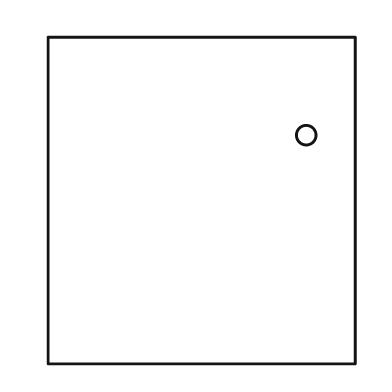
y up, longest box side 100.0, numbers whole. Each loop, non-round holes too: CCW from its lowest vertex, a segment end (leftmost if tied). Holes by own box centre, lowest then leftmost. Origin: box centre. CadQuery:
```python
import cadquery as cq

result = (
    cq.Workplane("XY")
    .moveTo(-47.0, -50.0)
    .lineTo(47.0, -50.0)
    .lineTo(47.0, 50.0)
    .lineTo(-47.0, 50.0)
    .close()
    .moveTo(32.0, 20.0)
    .circle(3.0)
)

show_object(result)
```